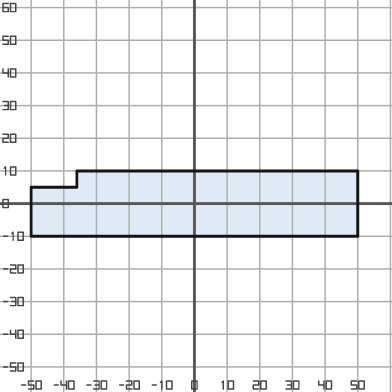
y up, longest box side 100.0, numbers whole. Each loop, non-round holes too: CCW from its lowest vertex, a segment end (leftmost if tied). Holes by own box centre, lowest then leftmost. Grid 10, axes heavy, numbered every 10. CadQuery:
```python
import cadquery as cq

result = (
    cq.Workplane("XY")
    .moveTo(-50.0, -10.0)
    .lineTo(50.0, -10.0)
    .lineTo(50.0, 10.0)
    .lineTo(-36.0, 10.0)
    .lineTo(-36.0, 5.0)
    .lineTo(-50.0, 5.0)
    .close()
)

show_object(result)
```